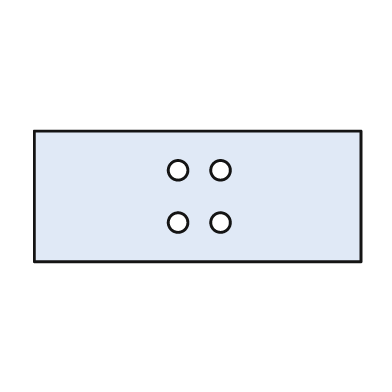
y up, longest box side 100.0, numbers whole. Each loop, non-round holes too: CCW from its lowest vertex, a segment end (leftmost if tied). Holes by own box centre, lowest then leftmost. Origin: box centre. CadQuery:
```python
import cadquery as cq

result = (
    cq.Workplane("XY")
    .moveTo(-50.0, -20.0)
    .lineTo(50.0, -20.0)
    .lineTo(50.0, 20.0)
    .lineTo(-50.0, 20.0)
    .close()
    .moveTo(-6.0, -8.0)
    .circle(3.0)
    .moveTo(7.0, -8.0)
    .circle(3.0)
    .moveTo(-6.0, 8.0)
    .circle(3.0)
    .moveTo(7.0, 8.0)
    .circle(3.0)
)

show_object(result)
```